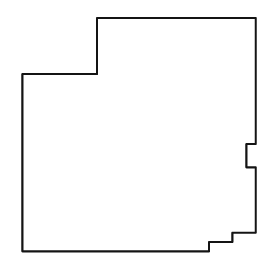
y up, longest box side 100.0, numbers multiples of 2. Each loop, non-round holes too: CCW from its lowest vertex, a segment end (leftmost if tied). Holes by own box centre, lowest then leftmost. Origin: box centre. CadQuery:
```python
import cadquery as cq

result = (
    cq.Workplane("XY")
    .moveTo(-50.0, -50.0)
    .lineTo(30.0, -50.0)
    .lineTo(30.0, -46.0)
    .lineTo(40.0, -46.0)
    .lineTo(40.0, -42.0)
    .lineTo(50.0, -42.0)
    .lineTo(50.0, -14.0)
    .lineTo(46.0, -14.0)
    .lineTo(46.0, -4.0)
    .lineTo(50.0, -4.0)
    .lineTo(50.0, 50.0)
    .lineTo(-18.0, 50.0)
    .lineTo(-18.0, 26.0)
    .lineTo(-50.0, 26.0)
    .close()
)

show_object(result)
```